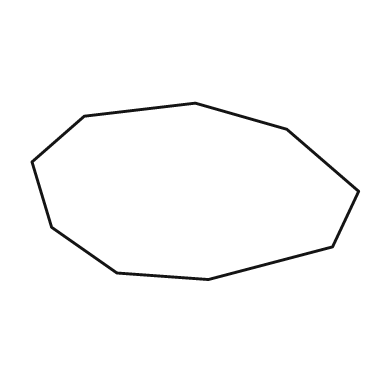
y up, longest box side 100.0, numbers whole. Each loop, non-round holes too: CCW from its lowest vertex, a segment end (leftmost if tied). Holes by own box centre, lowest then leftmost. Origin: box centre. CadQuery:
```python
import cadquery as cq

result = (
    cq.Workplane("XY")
    .moveTo(4.0, -27.0)
    .lineTo(42.0, -17.0)
    .lineTo(50.0, 0.0)
    .lineTo(28.0, 19.0)
    .lineTo(0.0, 27.0)
    .lineTo(-34.0, 23.0)
    .lineTo(-50.0, 9.0)
    .lineTo(-44.0, -11.0)
    .lineTo(-24.0, -25.0)
    .close()
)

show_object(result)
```